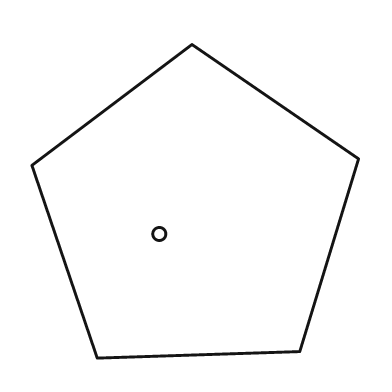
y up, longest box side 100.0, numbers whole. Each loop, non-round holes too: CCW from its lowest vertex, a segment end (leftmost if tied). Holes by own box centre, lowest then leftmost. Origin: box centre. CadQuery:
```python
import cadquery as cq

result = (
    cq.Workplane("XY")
    .moveTo(-30.0, -48.0)
    .lineTo(32.0, -46.0)
    .lineTo(50.0, 13.0)
    .lineTo(-1.0, 48.0)
    .lineTo(-50.0, 11.0)
    .close()
    .moveTo(-11.0, -10.0)
    .circle(2.0)
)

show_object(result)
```